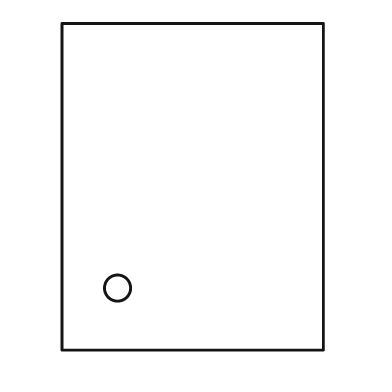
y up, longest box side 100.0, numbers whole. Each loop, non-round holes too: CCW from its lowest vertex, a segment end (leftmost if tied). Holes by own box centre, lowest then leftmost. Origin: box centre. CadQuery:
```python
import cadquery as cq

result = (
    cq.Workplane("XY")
    .moveTo(-40.0, -50.0)
    .lineTo(40.0, -50.0)
    .lineTo(40.0, 50.0)
    .lineTo(-40.0, 50.0)
    .close()
    .moveTo(-23.0, -31.0)
    .circle(4.0)
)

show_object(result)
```